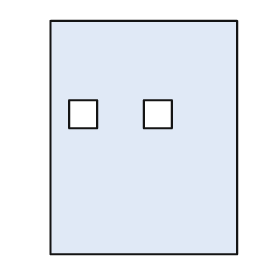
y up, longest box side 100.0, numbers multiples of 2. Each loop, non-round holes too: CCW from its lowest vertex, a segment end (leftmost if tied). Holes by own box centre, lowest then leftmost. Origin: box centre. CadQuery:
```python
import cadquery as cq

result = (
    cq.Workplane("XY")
    .moveTo(-40.0, -50.0)
    .lineTo(40.0, -50.0)
    .lineTo(40.0, 50.0)
    .lineTo(-40.0, 50.0)
    .close()
    .moveTo(-32.0, 4.0)
    .lineTo(-20.0, 4.0)
    .lineTo(-20.0, 16.0)
    .lineTo(-32.0, 16.0)
    .close()
    .moveTo(0.0, 4.0)
    .lineTo(12.0, 4.0)
    .lineTo(12.0, 16.0)
    .lineTo(0.0, 16.0)
    .close()
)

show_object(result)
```